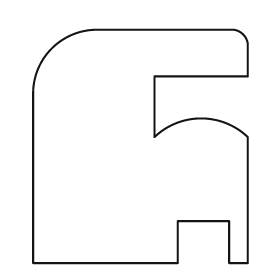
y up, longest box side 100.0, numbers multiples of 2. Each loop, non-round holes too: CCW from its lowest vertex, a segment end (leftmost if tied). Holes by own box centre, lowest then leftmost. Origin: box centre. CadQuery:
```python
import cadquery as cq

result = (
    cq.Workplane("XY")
    .moveTo(-46.0, -50.0)
    .lineTo(16.0, -50.0)
    .lineTo(16.0, -32.0)
    .lineTo(38.0, -32.0)
    .lineTo(38.0, -50.0)
    .lineTo(46.0, -50.0)
    .lineTo(46.0, 4.0)
    .threePointArc((26.0, 12.0), (6.0, 4.0))
    .lineTo(6.0, 30.0)
    .lineTo(46.0, 30.0)
    .lineTo(46.0, 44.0)
    .threePointArc((44.0, 48.0), (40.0, 50.0))
    .lineTo(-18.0, 50.0)
    .threePointArc((-38.0, 42.0), (-46.0, 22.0))
    .close()
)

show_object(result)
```